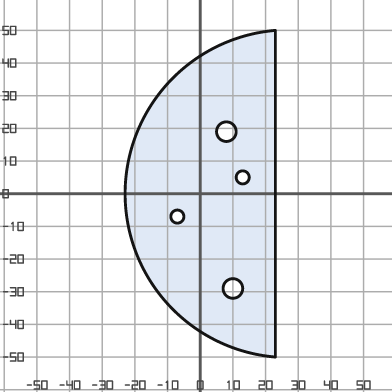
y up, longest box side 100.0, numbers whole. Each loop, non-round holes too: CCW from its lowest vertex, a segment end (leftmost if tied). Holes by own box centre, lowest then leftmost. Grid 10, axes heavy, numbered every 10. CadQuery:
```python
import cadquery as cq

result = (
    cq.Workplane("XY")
    .moveTo(23.0, -50.0)
    .lineTo(23.0, 50.0)
    .threePointArc((-23.0, 0.0), (23.0, -50.0))
    .close()
    .moveTo(10.0, -29.0)
    .circle(3.0)
    .moveTo(-7.0, -7.0)
    .circle(2.0)
    .moveTo(13.0, 5.0)
    .circle(2.0)
    .moveTo(8.0, 19.0)
    .circle(3.0)
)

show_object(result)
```